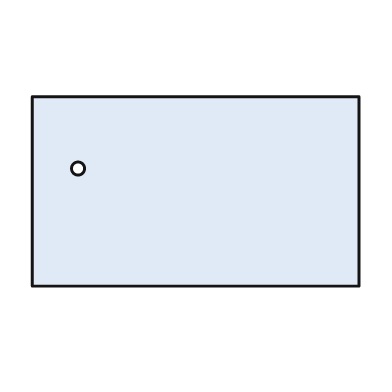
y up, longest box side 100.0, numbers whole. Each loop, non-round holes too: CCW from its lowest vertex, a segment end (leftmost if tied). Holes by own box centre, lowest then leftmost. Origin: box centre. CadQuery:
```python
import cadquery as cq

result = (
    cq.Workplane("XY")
    .moveTo(-50.0, -29.0)
    .lineTo(50.0, -29.0)
    .lineTo(50.0, 29.0)
    .lineTo(-50.0, 29.0)
    .close()
    .moveTo(-36.0, 7.0)
    .circle(2.0)
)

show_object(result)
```